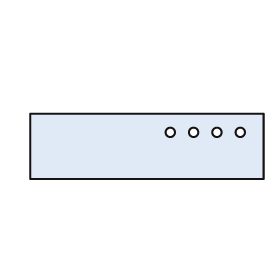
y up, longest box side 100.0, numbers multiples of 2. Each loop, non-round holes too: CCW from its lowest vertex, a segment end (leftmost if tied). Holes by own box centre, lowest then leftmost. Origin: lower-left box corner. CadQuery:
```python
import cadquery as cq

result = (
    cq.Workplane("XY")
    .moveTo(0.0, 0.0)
    .lineTo(100.0, 0.0)
    .lineTo(100.0, 28.0)
    .lineTo(0.0, 28.0)
    .close()
    .moveTo(60.0, 20.0)
    .circle(2.0)
    .moveTo(70.0, 20.0)
    .circle(2.0)
    .moveTo(80.0, 20.0)
    .circle(2.0)
    .moveTo(90.0, 20.0)
    .circle(2.0)
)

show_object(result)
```